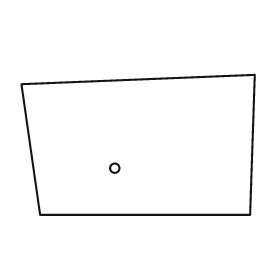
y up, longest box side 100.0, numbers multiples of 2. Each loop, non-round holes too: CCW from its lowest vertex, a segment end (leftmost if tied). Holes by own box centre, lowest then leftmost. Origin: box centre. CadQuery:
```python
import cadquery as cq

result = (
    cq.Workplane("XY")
    .moveTo(-42.0, -30.0)
    .lineTo(48.0, -30.0)
    .lineTo(50.0, 30.0)
    .lineTo(-50.0, 26.0)
    .close()
    .moveTo(-10.0, -10.0)
    .circle(2.0)
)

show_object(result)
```